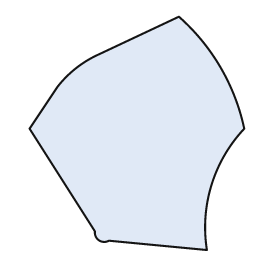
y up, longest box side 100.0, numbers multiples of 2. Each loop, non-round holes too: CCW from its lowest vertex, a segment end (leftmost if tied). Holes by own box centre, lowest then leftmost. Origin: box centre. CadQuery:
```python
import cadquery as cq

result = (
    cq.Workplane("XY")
    .moveTo(30.0, -50.0)
    .threePointArc((32.0, -22.0), (46.0, 2.0))
    .threePointArc((36.0, 28.0), (18.0, 50.0))
    .lineTo(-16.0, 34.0)
    .threePointArc((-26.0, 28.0), (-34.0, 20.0))
    .lineTo(-46.0, 2.0)
    .lineTo(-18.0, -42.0)
    .threePointArc((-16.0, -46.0), (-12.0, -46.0))
    .close()
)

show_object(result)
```